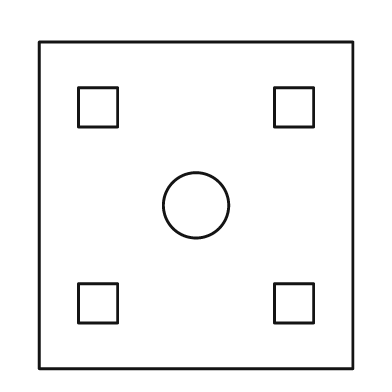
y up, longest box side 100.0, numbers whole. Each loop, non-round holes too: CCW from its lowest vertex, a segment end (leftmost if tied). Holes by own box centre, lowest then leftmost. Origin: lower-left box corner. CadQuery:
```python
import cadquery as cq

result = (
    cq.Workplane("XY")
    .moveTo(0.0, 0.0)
    .lineTo(96.0, 0.0)
    .lineTo(96.0, 100.0)
    .lineTo(0.0, 100.0)
    .close()
    .moveTo(12.0, 14.0)
    .lineTo(24.0, 14.0)
    .lineTo(24.0, 26.0)
    .lineTo(12.0, 26.0)
    .close()
    .moveTo(72.0, 14.0)
    .lineTo(84.0, 14.0)
    .lineTo(84.0, 26.0)
    .lineTo(72.0, 26.0)
    .close()
    .moveTo(48.0, 50.0)
    .circle(10.0)
    .moveTo(12.0, 74.0)
    .lineTo(24.0, 74.0)
    .lineTo(24.0, 86.0)
    .lineTo(12.0, 86.0)
    .close()
    .moveTo(72.0, 74.0)
    .lineTo(84.0, 74.0)
    .lineTo(84.0, 86.0)
    .lineTo(72.0, 86.0)
    .close()
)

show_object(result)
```